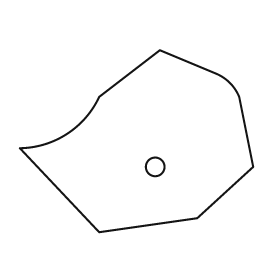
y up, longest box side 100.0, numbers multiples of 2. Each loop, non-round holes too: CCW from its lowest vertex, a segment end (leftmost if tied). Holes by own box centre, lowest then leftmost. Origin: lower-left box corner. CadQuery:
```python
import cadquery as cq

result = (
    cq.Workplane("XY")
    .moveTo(34.0, 0.0)
    .lineTo(76.0, 6.0)
    .lineTo(100.0, 28.0)
    .lineTo(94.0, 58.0)
    .threePointArc((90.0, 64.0), (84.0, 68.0))
    .lineTo(60.0, 78.0)
    .lineTo(34.0, 58.0)
    .threePointArc((20.0, 42.0), (0.0, 36.0))
    .close()
    .moveTo(58.0, 28.0)
    .circle(4.0)
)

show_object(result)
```